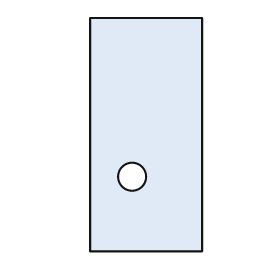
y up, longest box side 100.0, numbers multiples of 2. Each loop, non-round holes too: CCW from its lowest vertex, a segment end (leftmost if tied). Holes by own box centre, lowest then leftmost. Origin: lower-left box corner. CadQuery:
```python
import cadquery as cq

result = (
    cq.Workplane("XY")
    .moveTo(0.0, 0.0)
    .lineTo(48.0, 0.0)
    .lineTo(48.0, 100.0)
    .lineTo(0.0, 100.0)
    .close()
    .moveTo(18.0, 32.0)
    .circle(6.0)
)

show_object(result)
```